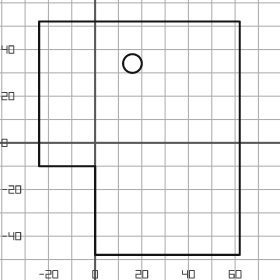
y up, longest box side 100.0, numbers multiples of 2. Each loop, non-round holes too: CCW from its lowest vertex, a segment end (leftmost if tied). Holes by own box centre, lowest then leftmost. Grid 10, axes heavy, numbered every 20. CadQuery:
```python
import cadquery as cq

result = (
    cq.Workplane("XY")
    .moveTo(0.0, -48.0)
    .lineTo(62.0, -48.0)
    .lineTo(62.0, 52.0)
    .lineTo(-24.0, 52.0)
    .lineTo(-24.0, -10.0)
    .lineTo(0.0, -10.0)
    .close()
    .moveTo(16.0, 34.0)
    .circle(4.0)
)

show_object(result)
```